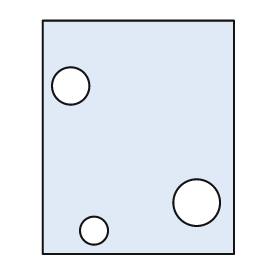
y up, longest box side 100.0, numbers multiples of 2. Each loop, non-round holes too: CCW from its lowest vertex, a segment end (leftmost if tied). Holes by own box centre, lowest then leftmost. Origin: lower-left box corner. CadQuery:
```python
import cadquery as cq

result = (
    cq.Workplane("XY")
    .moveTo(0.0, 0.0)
    .lineTo(82.0, 0.0)
    .lineTo(82.0, 100.0)
    .lineTo(0.0, 100.0)
    .close()
    .moveTo(22.0, 10.0)
    .circle(6.0)
    .moveTo(66.0, 22.0)
    .circle(10.0)
    .moveTo(12.0, 72.0)
    .circle(8.0)
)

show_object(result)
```